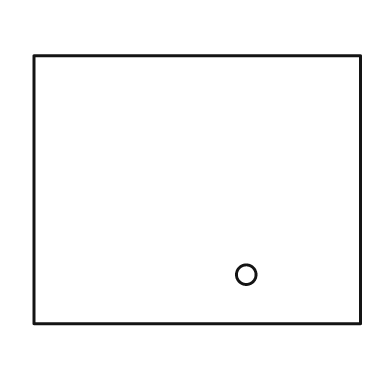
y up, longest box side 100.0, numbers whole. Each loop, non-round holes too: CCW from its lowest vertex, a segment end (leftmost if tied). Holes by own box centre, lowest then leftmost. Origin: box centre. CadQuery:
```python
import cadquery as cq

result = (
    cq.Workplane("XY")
    .moveTo(-50.0, -41.0)
    .lineTo(50.0, -41.0)
    .lineTo(50.0, 41.0)
    .lineTo(-50.0, 41.0)
    .close()
    .moveTo(15.0, -26.0)
    .circle(3.0)
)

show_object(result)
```